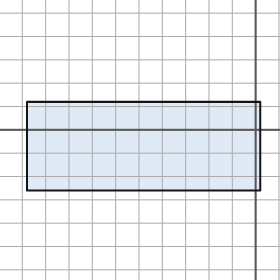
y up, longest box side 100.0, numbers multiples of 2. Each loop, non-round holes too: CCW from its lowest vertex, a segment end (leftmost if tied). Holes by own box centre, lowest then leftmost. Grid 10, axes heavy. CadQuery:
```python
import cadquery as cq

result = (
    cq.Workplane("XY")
    .moveTo(-98.0, -26.0)
    .lineTo(2.0, -26.0)
    .lineTo(2.0, 12.0)
    .lineTo(-98.0, 12.0)
    .close()
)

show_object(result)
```